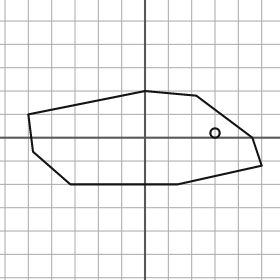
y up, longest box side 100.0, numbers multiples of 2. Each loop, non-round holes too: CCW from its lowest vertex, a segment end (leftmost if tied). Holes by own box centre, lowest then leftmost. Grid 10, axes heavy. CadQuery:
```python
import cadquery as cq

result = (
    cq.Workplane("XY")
    .moveTo(-32.0, -20.0)
    .lineTo(14.0, -20.0)
    .lineTo(50.0, -12.0)
    .lineTo(46.0, 0.0)
    .lineTo(22.0, 18.0)
    .lineTo(0.0, 20.0)
    .lineTo(-50.0, 10.0)
    .lineTo(-48.0, -6.0)
    .close()
    .moveTo(30.0, 2.0)
    .circle(2.0)
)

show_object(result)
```